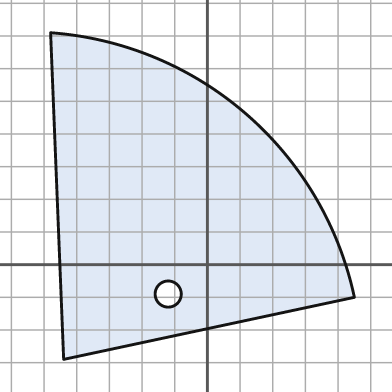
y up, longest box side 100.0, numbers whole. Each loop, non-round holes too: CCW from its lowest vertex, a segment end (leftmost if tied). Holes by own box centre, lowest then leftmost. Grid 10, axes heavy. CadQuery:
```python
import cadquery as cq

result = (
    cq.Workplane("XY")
    .moveTo(-44.0, -29.0)
    .lineTo(45.0, -10.0)
    .threePointArc((12.0, 46.0), (-48.0, 71.0))
    .close()
    .moveTo(-12.0, -9.0)
    .circle(4.0)
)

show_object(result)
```